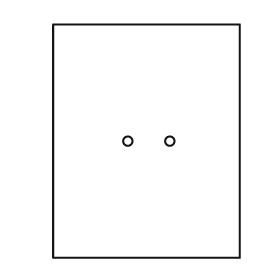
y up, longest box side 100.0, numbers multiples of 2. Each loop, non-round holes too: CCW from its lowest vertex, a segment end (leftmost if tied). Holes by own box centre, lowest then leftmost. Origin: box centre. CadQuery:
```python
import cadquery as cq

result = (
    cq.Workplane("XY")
    .moveTo(-40.0, -50.0)
    .lineTo(40.0, -50.0)
    .lineTo(40.0, 50.0)
    .lineTo(-40.0, 50.0)
    .close()
    .moveTo(-8.0, 0.0)
    .circle(2.0)
    .moveTo(10.0, 0.0)
    .circle(2.0)
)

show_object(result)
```